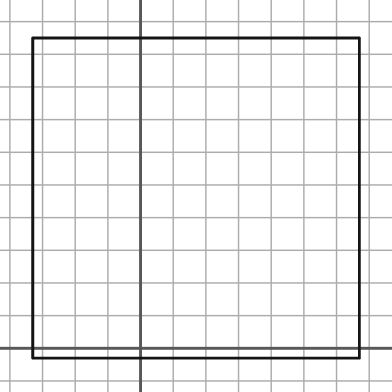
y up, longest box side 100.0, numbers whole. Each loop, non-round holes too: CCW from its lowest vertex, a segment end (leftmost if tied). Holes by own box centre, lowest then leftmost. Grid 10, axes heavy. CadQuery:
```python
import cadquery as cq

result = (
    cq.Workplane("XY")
    .moveTo(-33.0, -3.0)
    .lineTo(67.0, -3.0)
    .lineTo(67.0, 95.0)
    .lineTo(-33.0, 95.0)
    .close()
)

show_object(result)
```